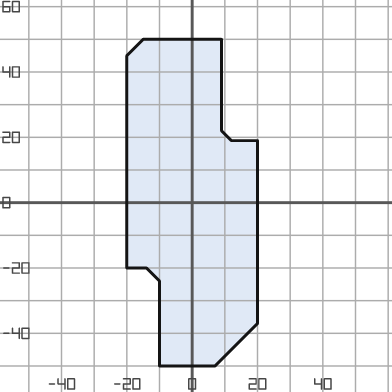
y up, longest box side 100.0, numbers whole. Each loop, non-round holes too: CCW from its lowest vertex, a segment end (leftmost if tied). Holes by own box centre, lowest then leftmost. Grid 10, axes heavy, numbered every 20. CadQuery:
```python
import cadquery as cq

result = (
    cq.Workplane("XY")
    .moveTo(-10.0, -50.0)
    .lineTo(7.0, -50.0)
    .lineTo(20.0, -37.0)
    .lineTo(20.0, 19.0)
    .lineTo(12.0, 19.0)
    .lineTo(9.0, 22.0)
    .lineTo(9.0, 50.0)
    .lineTo(-15.0, 50.0)
    .lineTo(-20.0, 45.0)
    .lineTo(-20.0, -20.0)
    .lineTo(-14.0, -20.0)
    .lineTo(-10.0, -24.0)
    .close()
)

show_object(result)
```